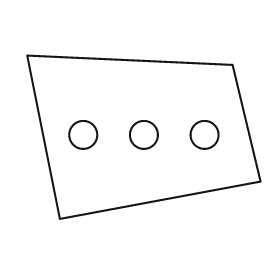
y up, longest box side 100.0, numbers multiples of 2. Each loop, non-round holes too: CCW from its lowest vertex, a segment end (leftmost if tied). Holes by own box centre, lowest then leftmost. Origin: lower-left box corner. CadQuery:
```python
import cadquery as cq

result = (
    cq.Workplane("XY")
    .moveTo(14.0, 0.0)
    .lineTo(100.0, 16.0)
    .lineTo(88.0, 66.0)
    .lineTo(0.0, 70.0)
    .close()
    .moveTo(24.0, 36.0)
    .circle(6.0)
    .moveTo(50.0, 36.0)
    .circle(6.0)
    .moveTo(76.0, 36.0)
    .circle(6.0)
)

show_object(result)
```